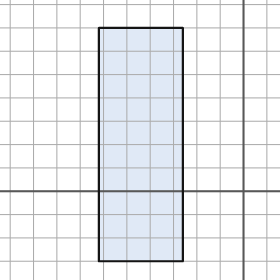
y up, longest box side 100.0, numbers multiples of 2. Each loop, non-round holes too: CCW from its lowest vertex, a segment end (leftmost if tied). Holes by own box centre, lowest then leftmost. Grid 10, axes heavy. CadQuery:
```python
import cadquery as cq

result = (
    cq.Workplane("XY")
    .moveTo(-62.0, -30.0)
    .lineTo(-26.0, -30.0)
    .lineTo(-26.0, 70.0)
    .lineTo(-62.0, 70.0)
    .close()
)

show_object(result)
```